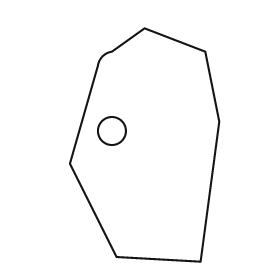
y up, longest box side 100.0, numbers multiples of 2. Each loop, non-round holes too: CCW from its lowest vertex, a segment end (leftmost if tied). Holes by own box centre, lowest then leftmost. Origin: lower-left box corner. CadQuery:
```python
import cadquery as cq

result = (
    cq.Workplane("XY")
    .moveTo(56.0, 0.0)
    .lineTo(64.0, 60.0)
    .lineTo(58.0, 90.0)
    .lineTo(32.0, 100.0)
    .lineTo(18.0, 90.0)
    .threePointArc((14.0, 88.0), (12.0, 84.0))
    .lineTo(0.0, 42.0)
    .lineTo(20.0, 2.0)
    .close()
    .moveTo(18.0, 56.0)
    .circle(6.0)
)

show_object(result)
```